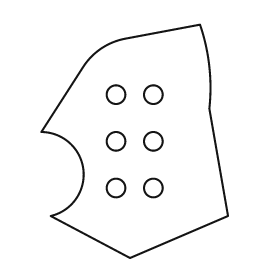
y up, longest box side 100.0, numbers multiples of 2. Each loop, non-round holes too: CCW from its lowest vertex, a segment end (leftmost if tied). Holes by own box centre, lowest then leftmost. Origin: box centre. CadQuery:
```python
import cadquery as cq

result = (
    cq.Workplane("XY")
    .moveTo(-2.0, -50.0)
    .lineTo(40.0, -32.0)
    .lineTo(32.0, 14.0)
    .threePointArc((32.0, 32.0), (28.0, 50.0))
    .lineTo(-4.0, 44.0)
    .threePointArc((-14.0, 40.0), (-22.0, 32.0))
    .lineTo(-40.0, 4.0)
    .threePointArc((-22.0, -12.0), (-36.0, -32.0))
    .close()
    .moveTo(-8.0, -20.0)
    .circle(4.0)
    .moveTo(8.0, -20.0)
    .circle(4.0)
    .moveTo(-8.0, 0.0)
    .circle(4.0)
    .moveTo(8.0, 0.0)
    .circle(4.0)
    .moveTo(-8.0, 20.0)
    .circle(4.0)
    .moveTo(8.0, 20.0)
    .circle(4.0)
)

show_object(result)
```